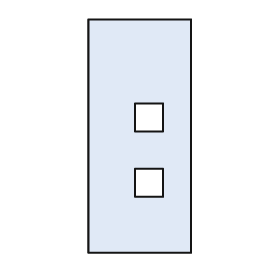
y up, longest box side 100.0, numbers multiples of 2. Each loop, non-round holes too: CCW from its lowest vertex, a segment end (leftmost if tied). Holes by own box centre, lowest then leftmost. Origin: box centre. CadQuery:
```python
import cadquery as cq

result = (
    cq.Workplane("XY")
    .moveTo(-22.0, -50.0)
    .lineTo(22.0, -50.0)
    .lineTo(22.0, 50.0)
    .lineTo(-22.0, 50.0)
    .close()
    .moveTo(-2.0, -26.0)
    .lineTo(10.0, -26.0)
    .lineTo(10.0, -14.0)
    .lineTo(-2.0, -14.0)
    .close()
    .moveTo(-2.0, 2.0)
    .lineTo(10.0, 2.0)
    .lineTo(10.0, 14.0)
    .lineTo(-2.0, 14.0)
    .close()
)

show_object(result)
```